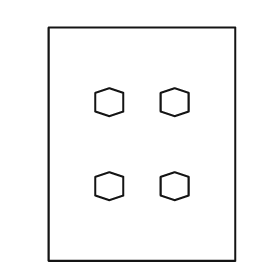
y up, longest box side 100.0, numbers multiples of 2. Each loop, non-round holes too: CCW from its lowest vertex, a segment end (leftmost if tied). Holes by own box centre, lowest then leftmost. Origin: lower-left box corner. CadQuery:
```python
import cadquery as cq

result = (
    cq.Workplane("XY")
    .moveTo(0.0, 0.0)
    .lineTo(80.0, 0.0)
    .lineTo(80.0, 100.0)
    .lineTo(0.0, 100.0)
    .close()
    .moveTo(26.0, 26.0)
    .lineTo(32.0, 28.0)
    .lineTo(32.0, 36.0)
    .lineTo(26.0, 38.0)
    .lineTo(20.0, 36.0)
    .lineTo(20.0, 28.0)
    .close()
    .moveTo(54.0, 26.0)
    .lineTo(60.0, 28.0)
    .lineTo(60.0, 36.0)
    .lineTo(54.0, 38.0)
    .lineTo(48.0, 36.0)
    .lineTo(48.0, 28.0)
    .close()
    .moveTo(26.0, 62.0)
    .lineTo(32.0, 64.0)
    .lineTo(32.0, 72.0)
    .lineTo(26.0, 74.0)
    .lineTo(20.0, 72.0)
    .lineTo(20.0, 64.0)
    .close()
    .moveTo(54.0, 62.0)
    .lineTo(60.0, 64.0)
    .lineTo(60.0, 72.0)
    .lineTo(54.0, 74.0)
    .lineTo(48.0, 72.0)
    .lineTo(48.0, 64.0)
    .close()
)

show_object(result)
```